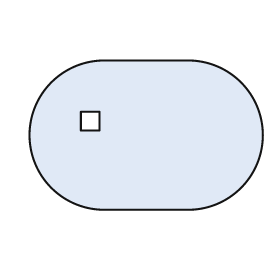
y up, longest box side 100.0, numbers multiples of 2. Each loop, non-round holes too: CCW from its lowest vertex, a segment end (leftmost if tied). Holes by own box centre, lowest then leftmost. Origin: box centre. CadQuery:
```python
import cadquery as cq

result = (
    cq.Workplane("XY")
    .moveTo(-18.0, -32.0)
    .lineTo(18.0, -32.0)
    .threePointArc((50.0, 0.0), (18.0, 32.0))
    .lineTo(-18.0, 32.0)
    .threePointArc((-50.0, 0.0), (-18.0, -32.0))
    .close()
    .moveTo(-28.0, 2.0)
    .lineTo(-20.0, 2.0)
    .lineTo(-20.0, 10.0)
    .lineTo(-28.0, 10.0)
    .close()
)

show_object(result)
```